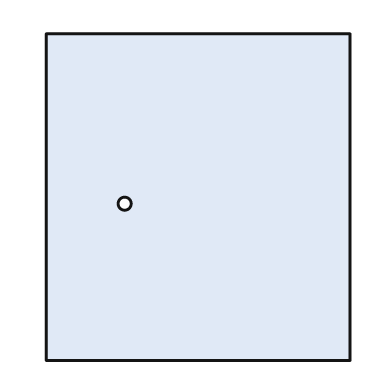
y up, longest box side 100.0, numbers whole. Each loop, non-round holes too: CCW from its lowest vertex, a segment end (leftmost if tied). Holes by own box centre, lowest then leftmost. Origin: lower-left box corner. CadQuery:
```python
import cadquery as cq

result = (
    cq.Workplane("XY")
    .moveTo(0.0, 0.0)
    .lineTo(93.0, 0.0)
    .lineTo(93.0, 100.0)
    .lineTo(0.0, 100.0)
    .close()
    .moveTo(24.0, 48.0)
    .circle(2.0)
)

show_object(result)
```